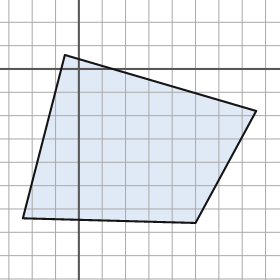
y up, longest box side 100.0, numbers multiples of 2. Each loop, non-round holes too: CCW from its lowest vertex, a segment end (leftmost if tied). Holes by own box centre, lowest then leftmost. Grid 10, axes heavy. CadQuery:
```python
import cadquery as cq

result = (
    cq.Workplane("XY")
    .moveTo(50.0, -66.0)
    .lineTo(76.0, -18.0)
    .lineTo(-6.0, 6.0)
    .lineTo(-24.0, -64.0)
    .close()
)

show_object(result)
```